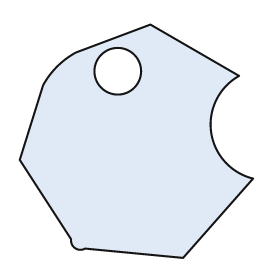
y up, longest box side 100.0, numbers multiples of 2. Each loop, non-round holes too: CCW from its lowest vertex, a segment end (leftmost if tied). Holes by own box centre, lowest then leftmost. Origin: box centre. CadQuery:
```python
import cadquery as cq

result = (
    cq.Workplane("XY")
    .moveTo(20.0, -50.0)
    .lineTo(50.0, -16.0)
    .threePointArc((32.0, 4.0), (44.0, 28.0))
    .lineTo(6.0, 50.0)
    .lineTo(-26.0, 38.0)
    .threePointArc((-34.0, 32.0), (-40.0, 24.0))
    .lineTo(-50.0, -8.0)
    .lineTo(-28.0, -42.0)
    .threePointArc((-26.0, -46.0), (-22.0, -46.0))
    .close()
    .moveTo(-8.0, 30.0)
    .circle(10.0)
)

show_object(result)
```